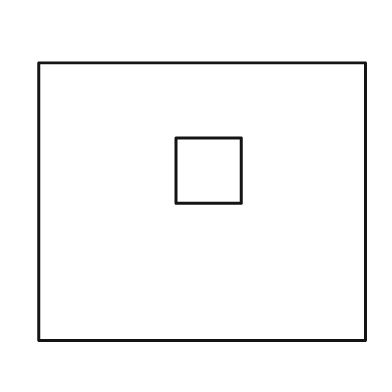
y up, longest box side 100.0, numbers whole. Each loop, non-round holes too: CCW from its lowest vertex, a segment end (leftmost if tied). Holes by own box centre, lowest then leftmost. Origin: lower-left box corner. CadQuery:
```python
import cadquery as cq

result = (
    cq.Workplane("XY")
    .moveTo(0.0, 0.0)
    .lineTo(100.0, 0.0)
    .lineTo(100.0, 85.0)
    .lineTo(0.0, 85.0)
    .close()
    .moveTo(42.0, 42.0)
    .lineTo(62.0, 42.0)
    .lineTo(62.0, 62.0)
    .lineTo(42.0, 62.0)
    .close()
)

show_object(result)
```